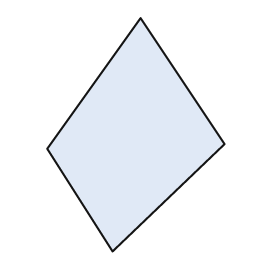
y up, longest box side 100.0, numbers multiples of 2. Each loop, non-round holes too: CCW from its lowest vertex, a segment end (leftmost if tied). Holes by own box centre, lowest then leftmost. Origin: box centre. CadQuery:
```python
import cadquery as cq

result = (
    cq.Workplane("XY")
    .moveTo(-10.0, -50.0)
    .lineTo(38.0, -4.0)
    .lineTo(2.0, 50.0)
    .lineTo(-38.0, -6.0)
    .close()
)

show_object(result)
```